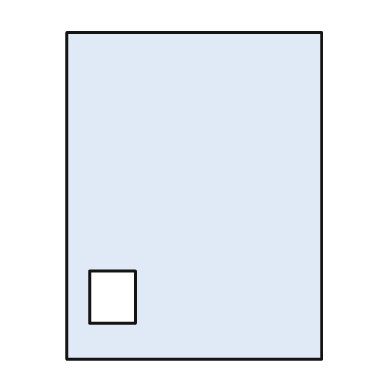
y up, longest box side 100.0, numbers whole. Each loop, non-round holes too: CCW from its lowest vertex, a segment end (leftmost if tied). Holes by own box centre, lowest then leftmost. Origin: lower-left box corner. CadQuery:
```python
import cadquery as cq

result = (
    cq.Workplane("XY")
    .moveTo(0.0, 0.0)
    .lineTo(78.0, 0.0)
    .lineTo(78.0, 100.0)
    .lineTo(0.0, 100.0)
    .close()
    .moveTo(7.0, 11.0)
    .lineTo(21.0, 11.0)
    .lineTo(21.0, 27.0)
    .lineTo(7.0, 27.0)
    .close()
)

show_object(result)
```